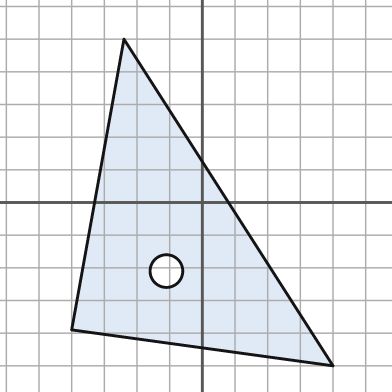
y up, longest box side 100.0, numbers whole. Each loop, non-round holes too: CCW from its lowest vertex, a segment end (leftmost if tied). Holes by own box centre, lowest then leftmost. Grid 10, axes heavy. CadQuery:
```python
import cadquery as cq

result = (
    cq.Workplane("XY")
    .moveTo(40.0, -50.0)
    .lineTo(-24.0, 50.0)
    .lineTo(-40.0, -39.0)
    .close()
    .moveTo(-11.0, -21.0)
    .circle(5.0)
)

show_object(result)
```